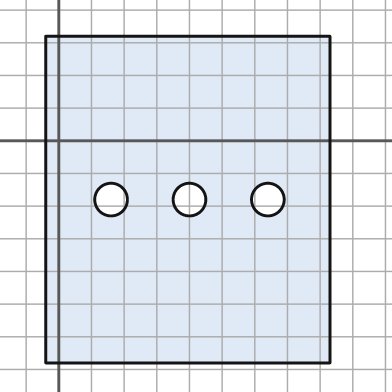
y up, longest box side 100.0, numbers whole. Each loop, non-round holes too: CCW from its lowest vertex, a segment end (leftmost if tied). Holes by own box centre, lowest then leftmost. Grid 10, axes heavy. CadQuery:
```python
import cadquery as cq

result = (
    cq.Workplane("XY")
    .moveTo(-4.0, -68.0)
    .lineTo(83.0, -68.0)
    .lineTo(83.0, 32.0)
    .lineTo(-4.0, 32.0)
    .close()
    .moveTo(16.0, -18.0)
    .circle(5.0)
    .moveTo(40.0, -18.0)
    .circle(5.0)
    .moveTo(64.0, -18.0)
    .circle(5.0)
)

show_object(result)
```